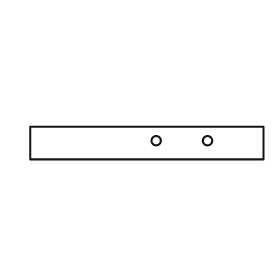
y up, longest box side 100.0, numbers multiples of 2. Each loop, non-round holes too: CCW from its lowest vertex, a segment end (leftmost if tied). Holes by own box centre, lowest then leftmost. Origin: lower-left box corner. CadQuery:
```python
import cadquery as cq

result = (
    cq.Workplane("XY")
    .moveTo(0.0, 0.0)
    .lineTo(100.0, 0.0)
    .lineTo(100.0, 14.0)
    .lineTo(0.0, 14.0)
    .close()
    .moveTo(54.0, 8.0)
    .circle(2.0)
    .moveTo(76.0, 8.0)
    .circle(2.0)
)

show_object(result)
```